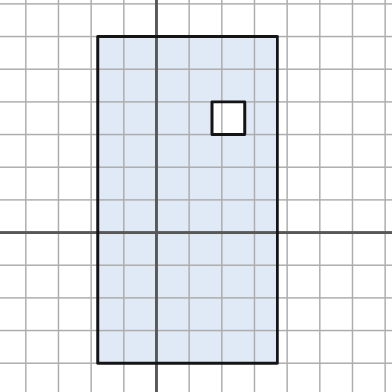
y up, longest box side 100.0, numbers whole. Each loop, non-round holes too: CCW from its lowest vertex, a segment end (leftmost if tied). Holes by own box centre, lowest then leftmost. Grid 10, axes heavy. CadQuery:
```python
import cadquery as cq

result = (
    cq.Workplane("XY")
    .moveTo(-18.0, -40.0)
    .lineTo(37.0, -40.0)
    .lineTo(37.0, 60.0)
    .lineTo(-18.0, 60.0)
    .close()
    .moveTo(17.0, 30.0)
    .lineTo(27.0, 30.0)
    .lineTo(27.0, 40.0)
    .lineTo(17.0, 40.0)
    .close()
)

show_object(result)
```